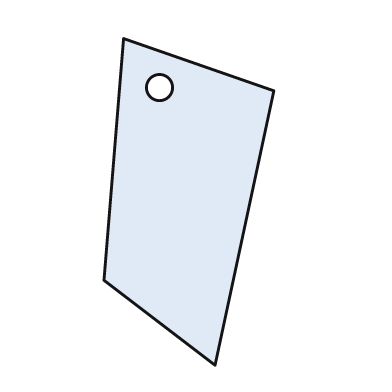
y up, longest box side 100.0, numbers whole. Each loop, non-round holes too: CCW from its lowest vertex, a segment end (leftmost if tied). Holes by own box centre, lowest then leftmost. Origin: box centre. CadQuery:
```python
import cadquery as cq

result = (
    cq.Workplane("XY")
    .moveTo(8.0, -50.0)
    .lineTo(26.0, 34.0)
    .lineTo(-20.0, 50.0)
    .lineTo(-26.0, -24.0)
    .close()
    .moveTo(-9.0, 35.0)
    .circle(4.0)
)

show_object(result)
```